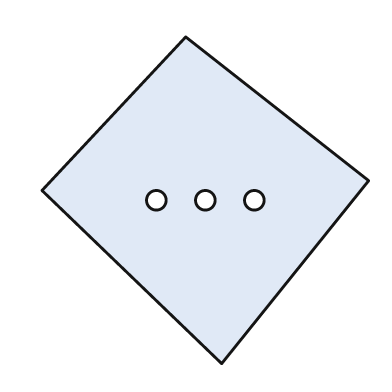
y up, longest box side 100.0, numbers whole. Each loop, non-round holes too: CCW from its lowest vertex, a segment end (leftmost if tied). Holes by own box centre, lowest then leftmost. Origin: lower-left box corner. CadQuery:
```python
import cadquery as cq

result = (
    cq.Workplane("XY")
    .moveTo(55.0, 0.0)
    .lineTo(100.0, 56.0)
    .lineTo(44.0, 100.0)
    .lineTo(0.0, 53.0)
    .close()
    .moveTo(35.0, 50.0)
    .circle(3.0)
    .moveTo(50.0, 50.0)
    .circle(3.0)
    .moveTo(65.0, 50.0)
    .circle(3.0)
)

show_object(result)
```